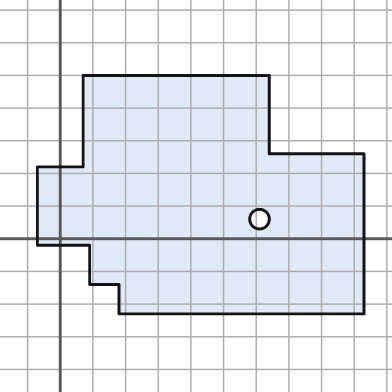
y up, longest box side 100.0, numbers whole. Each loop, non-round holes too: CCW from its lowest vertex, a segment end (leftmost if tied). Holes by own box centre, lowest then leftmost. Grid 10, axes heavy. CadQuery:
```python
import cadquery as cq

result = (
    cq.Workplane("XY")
    .moveTo(18.0, -23.0)
    .lineTo(93.0, -23.0)
    .lineTo(93.0, 26.0)
    .lineTo(64.0, 26.0)
    .lineTo(64.0, 50.0)
    .lineTo(7.0, 50.0)
    .lineTo(7.0, 22.0)
    .lineTo(-7.0, 22.0)
    .lineTo(-7.0, -2.0)
    .lineTo(9.0, -2.0)
    .lineTo(9.0, -14.0)
    .lineTo(18.0, -14.0)
    .close()
    .moveTo(61.0, 6.0)
    .circle(3.0)
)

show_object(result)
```